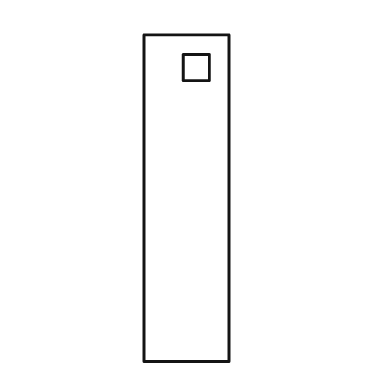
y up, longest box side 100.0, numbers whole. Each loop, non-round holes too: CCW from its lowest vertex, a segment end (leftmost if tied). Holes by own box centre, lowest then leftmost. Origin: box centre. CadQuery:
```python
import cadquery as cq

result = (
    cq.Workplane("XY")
    .moveTo(-13.0, -50.0)
    .lineTo(13.0, -50.0)
    .lineTo(13.0, 50.0)
    .lineTo(-13.0, 50.0)
    .close()
    .moveTo(-1.0, 36.0)
    .lineTo(7.0, 36.0)
    .lineTo(7.0, 44.0)
    .lineTo(-1.0, 44.0)
    .close()
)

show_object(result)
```